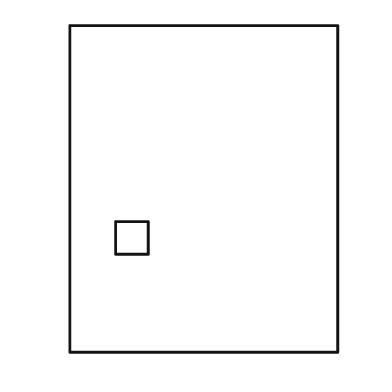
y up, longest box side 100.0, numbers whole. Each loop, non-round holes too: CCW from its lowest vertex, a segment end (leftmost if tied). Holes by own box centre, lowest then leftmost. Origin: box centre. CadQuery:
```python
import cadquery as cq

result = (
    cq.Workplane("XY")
    .moveTo(-41.0, -50.0)
    .lineTo(41.0, -50.0)
    .lineTo(41.0, 50.0)
    .lineTo(-41.0, 50.0)
    .close()
    .moveTo(-27.0, -20.0)
    .lineTo(-17.0, -20.0)
    .lineTo(-17.0, -10.0)
    .lineTo(-27.0, -10.0)
    .close()
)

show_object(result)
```